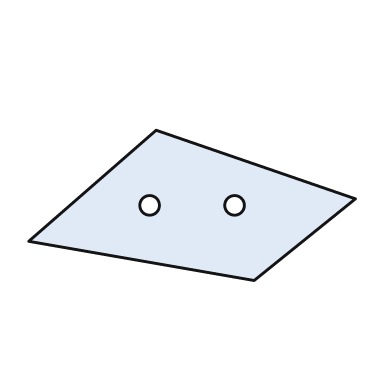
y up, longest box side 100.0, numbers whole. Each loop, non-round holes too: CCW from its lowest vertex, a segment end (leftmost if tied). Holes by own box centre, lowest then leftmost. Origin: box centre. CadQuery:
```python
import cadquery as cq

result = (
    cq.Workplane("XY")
    .moveTo(19.0, -23.0)
    .lineTo(50.0, 2.0)
    .lineTo(-11.0, 23.0)
    .lineTo(-50.0, -11.0)
    .close()
    .moveTo(-13.0, 0.0)
    .circle(3.0)
    .moveTo(13.0, 0.0)
    .circle(3.0)
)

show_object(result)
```